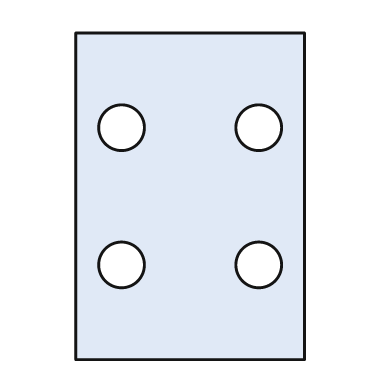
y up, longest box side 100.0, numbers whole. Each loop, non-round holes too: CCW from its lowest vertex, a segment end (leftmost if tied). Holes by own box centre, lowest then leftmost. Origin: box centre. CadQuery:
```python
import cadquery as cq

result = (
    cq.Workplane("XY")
    .moveTo(-35.0, -50.0)
    .lineTo(35.0, -50.0)
    .lineTo(35.0, 50.0)
    .lineTo(-35.0, 50.0)
    .close()
    .moveTo(-21.0, -21.0)
    .circle(7.0)
    .moveTo(21.0, -21.0)
    .circle(7.0)
    .moveTo(-21.0, 21.0)
    .circle(7.0)
    .moveTo(21.0, 21.0)
    .circle(7.0)
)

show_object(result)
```